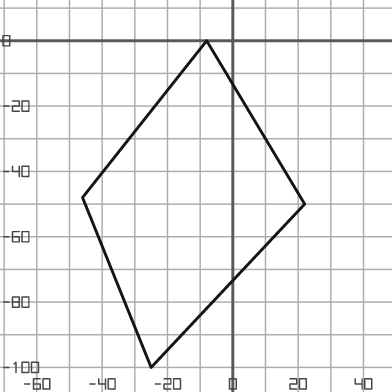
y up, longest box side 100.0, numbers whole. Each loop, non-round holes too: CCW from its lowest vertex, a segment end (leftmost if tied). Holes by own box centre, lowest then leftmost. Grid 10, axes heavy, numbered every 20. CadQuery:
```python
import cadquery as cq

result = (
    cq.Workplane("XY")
    .moveTo(-25.0, -100.0)
    .lineTo(22.0, -50.0)
    .lineTo(-8.0, 0.0)
    .lineTo(-46.0, -48.0)
    .close()
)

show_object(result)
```